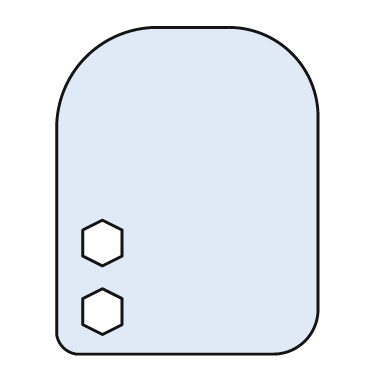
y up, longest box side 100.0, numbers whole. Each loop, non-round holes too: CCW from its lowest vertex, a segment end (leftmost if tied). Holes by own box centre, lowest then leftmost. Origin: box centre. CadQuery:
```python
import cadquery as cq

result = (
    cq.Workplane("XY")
    .moveTo(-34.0, -50.0)
    .lineTo(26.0, -50.0)
    .threePointArc((36.0, -46.0), (40.0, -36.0))
    .lineTo(40.0, 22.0)
    .threePointArc((32.0, 42.0), (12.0, 50.0))
    .lineTo(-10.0, 50.0)
    .threePointArc((-31.0, 41.0), (-40.0, 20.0))
    .lineTo(-40.0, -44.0)
    .threePointArc((-38.0, -48.0), (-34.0, -50.0))
    .close()
    .moveTo(-26.0, -44.0)
    .lineTo(-20.0, -41.0)
    .lineTo(-20.0, -33.0)
    .lineTo(-26.0, -30.0)
    .lineTo(-32.0, -33.0)
    .lineTo(-32.0, -41.0)
    .close()
    .moveTo(-26.0, -23.0)
    .lineTo(-20.0, -20.0)
    .lineTo(-20.0, -12.0)
    .lineTo(-26.0, -9.0)
    .lineTo(-32.0, -12.0)
    .lineTo(-32.0, -20.0)
    .close()
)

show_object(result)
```